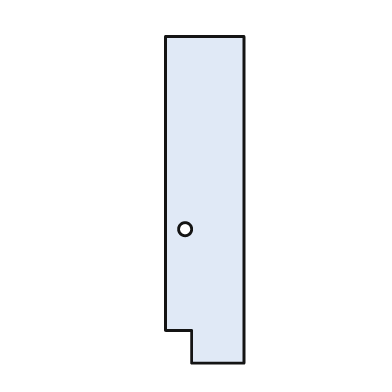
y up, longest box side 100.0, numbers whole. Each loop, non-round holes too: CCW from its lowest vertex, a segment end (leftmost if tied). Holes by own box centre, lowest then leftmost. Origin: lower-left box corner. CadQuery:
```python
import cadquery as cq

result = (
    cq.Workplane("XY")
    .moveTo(8.0, 0.0)
    .lineTo(24.0, 0.0)
    .lineTo(24.0, 100.0)
    .lineTo(0.0, 100.0)
    .lineTo(0.0, 10.0)
    .lineTo(8.0, 10.0)
    .close()
    .moveTo(6.0, 41.0)
    .circle(2.0)
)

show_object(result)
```